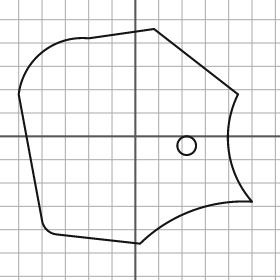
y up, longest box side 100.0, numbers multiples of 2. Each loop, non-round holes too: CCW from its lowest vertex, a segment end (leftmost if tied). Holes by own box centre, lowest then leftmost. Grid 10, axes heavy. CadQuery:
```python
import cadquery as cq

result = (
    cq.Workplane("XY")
    .moveTo(2.0, -46.0)
    .threePointArc((24.0, -32.0), (50.0, -28.0))
    .threePointArc((40.0, -6.0), (44.0, 18.0))
    .lineTo(8.0, 46.0)
    .lineTo(-20.0, 42.0)
    .threePointArc((-40.0, 36.0), (-50.0, 18.0))
    .lineTo(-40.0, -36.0)
    .threePointArc((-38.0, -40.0), (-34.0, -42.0))
    .close()
    .moveTo(22.0, -4.0)
    .circle(4.0)
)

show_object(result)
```